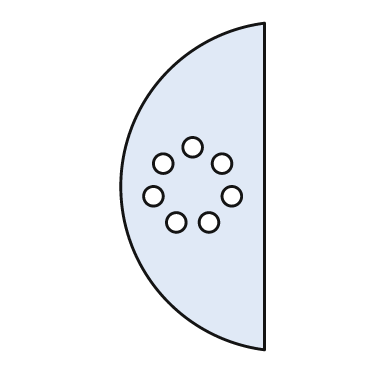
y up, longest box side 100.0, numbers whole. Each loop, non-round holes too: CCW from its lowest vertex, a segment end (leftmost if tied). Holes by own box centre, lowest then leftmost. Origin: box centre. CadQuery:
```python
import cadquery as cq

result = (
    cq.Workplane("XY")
    .moveTo(22.0, -50.0)
    .lineTo(22.0, 50.0)
    .threePointArc((-22.0, 0.0), (22.0, -50.0))
    .close()
    .moveTo(-5.0, -11.0)
    .circle(3.0)
    .moveTo(5.0, -11.0)
    .circle(3.0)
    .moveTo(-12.0, -3.0)
    .circle(3.0)
    .moveTo(12.0, -3.0)
    .circle(3.0)
    .moveTo(-9.0, 7.0)
    .circle(3.0)
    .moveTo(9.0, 7.0)
    .circle(3.0)
    .moveTo(0.0, 12.0)
    .circle(3.0)
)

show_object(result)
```